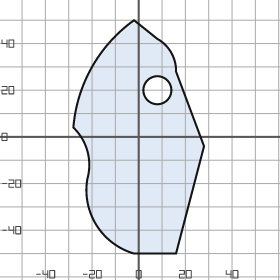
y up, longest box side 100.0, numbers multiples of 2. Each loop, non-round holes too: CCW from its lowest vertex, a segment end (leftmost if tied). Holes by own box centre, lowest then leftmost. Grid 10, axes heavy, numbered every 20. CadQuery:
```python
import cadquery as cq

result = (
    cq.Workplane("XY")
    .moveTo(-2.0, -50.0)
    .lineTo(16.0, -50.0)
    .lineTo(28.0, -4.0)
    .lineTo(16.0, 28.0)
    .threePointArc((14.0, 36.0), (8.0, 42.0))
    .lineTo(-2.0, 50.0)
    .threePointArc((-20.0, 30.0), (-28.0, 4.0))
    .threePointArc((-22.0, -6.0), (-22.0, -18.0))
    .threePointArc((-18.0, -38.0), (-2.0, -50.0))
    .close()
    .moveTo(8.0, 20.0)
    .circle(6.0)
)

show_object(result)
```